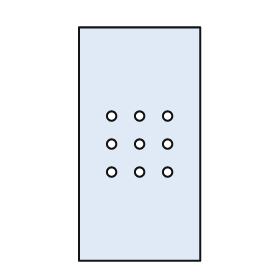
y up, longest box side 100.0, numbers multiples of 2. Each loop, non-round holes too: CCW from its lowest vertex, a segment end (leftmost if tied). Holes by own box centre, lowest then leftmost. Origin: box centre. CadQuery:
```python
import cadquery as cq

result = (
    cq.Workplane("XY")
    .moveTo(-26.0, -50.0)
    .lineTo(26.0, -50.0)
    .lineTo(26.0, 50.0)
    .lineTo(-26.0, 50.0)
    .close()
    .moveTo(-12.0, -12.0)
    .circle(2.0)
    .moveTo(0.0, -12.0)
    .circle(2.0)
    .moveTo(12.0, -12.0)
    .circle(2.0)
    .moveTo(-12.0, 0.0)
    .circle(2.0)
    .moveTo(0.0, 0.0)
    .circle(2.0)
    .moveTo(12.0, 0.0)
    .circle(2.0)
    .moveTo(-12.0, 12.0)
    .circle(2.0)
    .moveTo(0.0, 12.0)
    .circle(2.0)
    .moveTo(12.0, 12.0)
    .circle(2.0)
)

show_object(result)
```